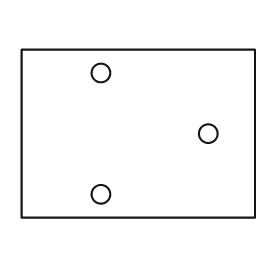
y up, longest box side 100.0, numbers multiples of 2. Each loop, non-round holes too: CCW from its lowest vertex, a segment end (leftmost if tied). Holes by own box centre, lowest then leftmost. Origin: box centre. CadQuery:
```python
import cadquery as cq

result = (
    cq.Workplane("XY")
    .moveTo(-50.0, -36.0)
    .lineTo(50.0, -36.0)
    .lineTo(50.0, 36.0)
    .lineTo(-50.0, 36.0)
    .close()
    .moveTo(-16.0, -26.0)
    .circle(4.0)
    .moveTo(30.0, 0.0)
    .circle(4.0)
    .moveTo(-16.0, 26.0)
    .circle(4.0)
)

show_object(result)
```